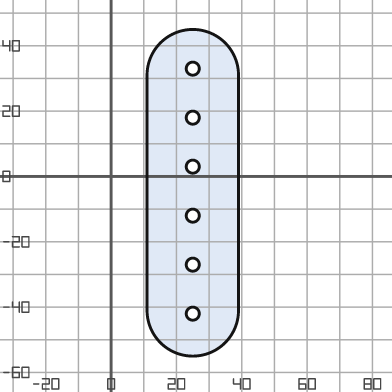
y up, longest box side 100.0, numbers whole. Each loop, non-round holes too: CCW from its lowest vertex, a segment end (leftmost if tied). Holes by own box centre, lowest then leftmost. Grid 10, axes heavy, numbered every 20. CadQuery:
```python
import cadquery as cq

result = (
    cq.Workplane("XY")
    .moveTo(11.0, -41.0)
    .threePointArc((25.0, -55.0), (39.0, -41.0))
    .lineTo(39.0, 31.0)
    .threePointArc((25.0, 45.0), (11.0, 31.0))
    .close()
    .moveTo(25.0, -42.0)
    .circle(2.0)
    .moveTo(25.0, -27.0)
    .circle(2.0)
    .moveTo(25.0, -12.0)
    .circle(2.0)
    .moveTo(25.0, 3.0)
    .circle(2.0)
    .moveTo(25.0, 18.0)
    .circle(2.0)
    .moveTo(25.0, 33.0)
    .circle(2.0)
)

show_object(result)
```